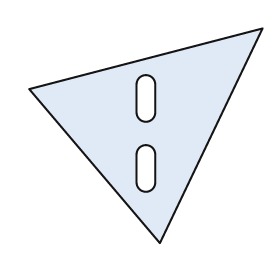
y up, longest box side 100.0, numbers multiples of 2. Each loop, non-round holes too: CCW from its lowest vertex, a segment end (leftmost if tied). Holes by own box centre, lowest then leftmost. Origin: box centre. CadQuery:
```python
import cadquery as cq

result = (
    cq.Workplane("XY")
    .moveTo(6.0, -46.0)
    .lineTo(50.0, 46.0)
    .lineTo(-50.0, 20.0)
    .close()
    .moveTo(-4.0, -20.0)
    .threePointArc((0.0, -24.0), (4.0, -20.0))
    .lineTo(4.0, -8.0)
    .threePointArc((0.0, -4.0), (-4.0, -8.0))
    .close()
    .moveTo(-4.0, 10.0)
    .threePointArc((0.0, 6.0), (4.0, 10.0))
    .lineTo(4.0, 22.0)
    .threePointArc((0.0, 26.0), (-4.0, 22.0))
    .close()
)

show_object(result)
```